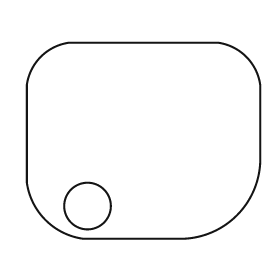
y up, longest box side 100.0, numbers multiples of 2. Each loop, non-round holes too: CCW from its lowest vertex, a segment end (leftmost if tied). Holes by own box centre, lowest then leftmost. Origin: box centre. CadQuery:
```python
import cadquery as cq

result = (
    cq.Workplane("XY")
    .moveTo(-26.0, -42.0)
    .lineTo(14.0, -42.0)
    .threePointArc((40.0, -32.0), (50.0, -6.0))
    .lineTo(50.0, 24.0)
    .threePointArc((44.0, 36.0), (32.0, 42.0))
    .lineTo(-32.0, 42.0)
    .threePointArc((-44.0, 36.0), (-50.0, 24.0))
    .lineTo(-50.0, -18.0)
    .threePointArc((-42.0, -34.0), (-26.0, -42.0))
    .close()
    .moveTo(-24.0, -28.0)
    .circle(10.0)
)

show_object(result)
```